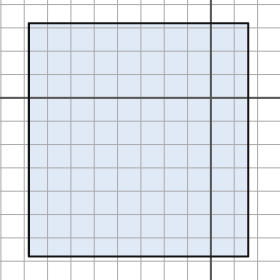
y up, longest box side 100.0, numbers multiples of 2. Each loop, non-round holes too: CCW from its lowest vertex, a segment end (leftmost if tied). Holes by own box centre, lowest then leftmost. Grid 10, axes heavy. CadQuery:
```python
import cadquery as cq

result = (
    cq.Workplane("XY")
    .moveTo(-78.0, -68.0)
    .lineTo(16.0, -68.0)
    .lineTo(16.0, 32.0)
    .lineTo(-78.0, 32.0)
    .close()
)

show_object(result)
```